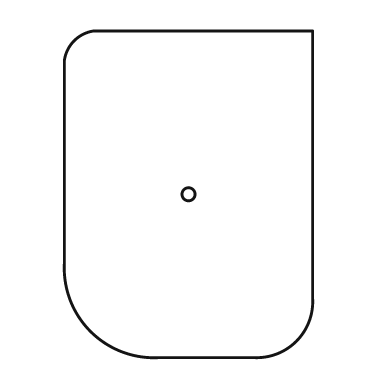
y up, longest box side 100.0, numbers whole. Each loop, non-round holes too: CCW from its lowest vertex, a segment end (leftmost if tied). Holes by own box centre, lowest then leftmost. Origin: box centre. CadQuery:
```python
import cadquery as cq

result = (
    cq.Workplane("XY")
    .moveTo(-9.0, -50.0)
    .lineTo(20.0, -50.0)
    .threePointArc((33.0, -45.0), (38.0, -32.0))
    .lineTo(38.0, 50.0)
    .lineTo(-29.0, 50.0)
    .threePointArc((-35.0, 47.0), (-38.0, 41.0))
    .lineTo(-38.0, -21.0)
    .threePointArc((-30.0, -42.0), (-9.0, -50.0))
    .close()
    .moveTo(0.0, 0.0)
    .circle(2.0)
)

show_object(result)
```